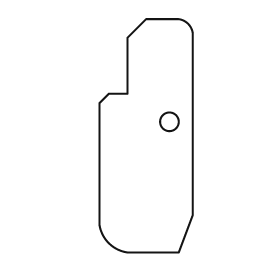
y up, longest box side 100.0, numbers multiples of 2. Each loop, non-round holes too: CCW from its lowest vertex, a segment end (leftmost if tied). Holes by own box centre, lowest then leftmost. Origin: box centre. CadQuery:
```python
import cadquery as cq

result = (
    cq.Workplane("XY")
    .moveTo(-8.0, -50.0)
    .lineTo(14.0, -50.0)
    .lineTo(20.0, -34.0)
    .lineTo(20.0, 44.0)
    .threePointArc((18.0, 48.0), (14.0, 50.0))
    .lineTo(0.0, 50.0)
    .lineTo(-8.0, 42.0)
    .lineTo(-8.0, 18.0)
    .lineTo(-16.0, 18.0)
    .lineTo(-20.0, 14.0)
    .lineTo(-20.0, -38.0)
    .threePointArc((-16.0, -46.0), (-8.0, -50.0))
    .close()
    .moveTo(10.0, 6.0)
    .circle(4.0)
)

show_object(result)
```